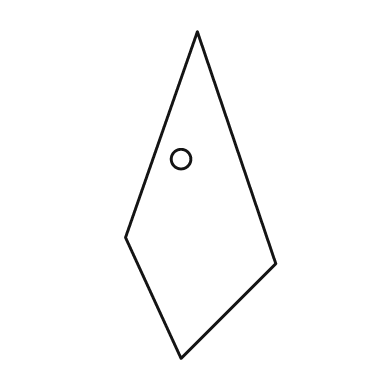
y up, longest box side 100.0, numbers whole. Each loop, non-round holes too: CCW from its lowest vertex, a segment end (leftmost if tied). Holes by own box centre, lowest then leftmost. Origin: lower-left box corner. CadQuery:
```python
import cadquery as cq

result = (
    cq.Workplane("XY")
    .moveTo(17.0, 0.0)
    .lineTo(46.0, 29.0)
    .lineTo(22.0, 100.0)
    .lineTo(0.0, 37.0)
    .close()
    .moveTo(17.0, 61.0)
    .circle(3.0)
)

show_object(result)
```